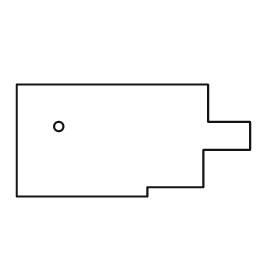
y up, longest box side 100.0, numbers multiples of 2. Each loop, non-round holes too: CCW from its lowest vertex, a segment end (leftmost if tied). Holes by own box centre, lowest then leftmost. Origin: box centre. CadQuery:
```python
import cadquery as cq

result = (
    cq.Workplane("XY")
    .moveTo(-50.0, -24.0)
    .lineTo(6.0, -24.0)
    .lineTo(6.0, -20.0)
    .lineTo(30.0, -20.0)
    .lineTo(30.0, -4.0)
    .lineTo(50.0, -4.0)
    .lineTo(50.0, 8.0)
    .lineTo(32.0, 8.0)
    .lineTo(32.0, 24.0)
    .lineTo(-50.0, 24.0)
    .close()
    .moveTo(-32.0, 6.0)
    .circle(2.0)
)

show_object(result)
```